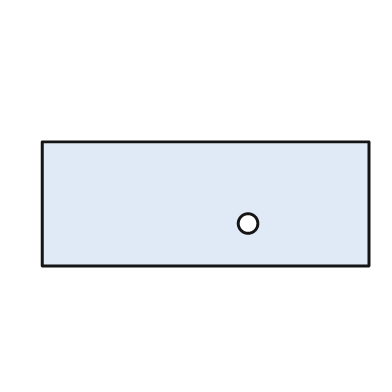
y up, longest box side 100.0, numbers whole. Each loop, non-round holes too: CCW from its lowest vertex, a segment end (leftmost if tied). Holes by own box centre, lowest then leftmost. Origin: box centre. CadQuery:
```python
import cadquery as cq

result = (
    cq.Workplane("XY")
    .moveTo(-50.0, -19.0)
    .lineTo(50.0, -19.0)
    .lineTo(50.0, 19.0)
    .lineTo(-50.0, 19.0)
    .close()
    .moveTo(13.0, -6.0)
    .circle(3.0)
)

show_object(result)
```